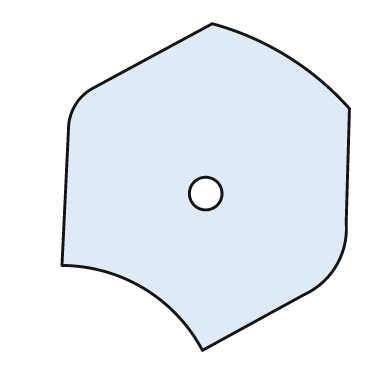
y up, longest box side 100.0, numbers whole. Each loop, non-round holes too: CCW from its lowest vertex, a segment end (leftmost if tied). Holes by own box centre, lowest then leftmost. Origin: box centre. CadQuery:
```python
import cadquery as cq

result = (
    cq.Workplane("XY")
    .moveTo(-1.0, -50.0)
    .lineTo(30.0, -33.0)
    .threePointArc((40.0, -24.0), (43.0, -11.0))
    .lineTo(44.0, 24.0)
    .threePointArc((25.0, 40.0), (2.0, 50.0))
    .lineTo(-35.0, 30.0)
    .threePointArc((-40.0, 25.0), (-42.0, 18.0))
    .lineTo(-44.0, -24.0)
    .threePointArc((-19.0, -31.0), (-1.0, -50.0))
    .close()
    .moveTo(0.0, -2.0)
    .circle(5.0)
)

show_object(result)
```